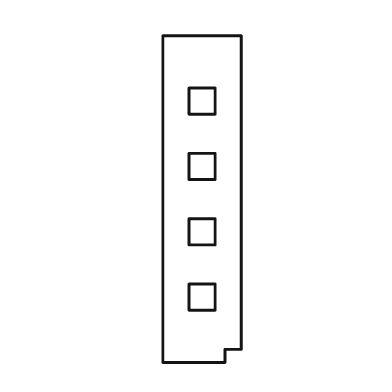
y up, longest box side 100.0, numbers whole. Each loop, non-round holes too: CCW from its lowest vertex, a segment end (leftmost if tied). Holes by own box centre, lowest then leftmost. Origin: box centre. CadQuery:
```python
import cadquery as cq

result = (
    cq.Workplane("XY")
    .moveTo(-12.0, -50.0)
    .lineTo(7.0, -50.0)
    .lineTo(7.0, -46.0)
    .lineTo(12.0, -46.0)
    .lineTo(12.0, 50.0)
    .lineTo(-12.0, 50.0)
    .close()
    .moveTo(-4.0, -34.0)
    .lineTo(4.0, -34.0)
    .lineTo(4.0, -26.0)
    .lineTo(-4.0, -26.0)
    .close()
    .moveTo(-4.0, -14.0)
    .lineTo(4.0, -14.0)
    .lineTo(4.0, -6.0)
    .lineTo(-4.0, -6.0)
    .close()
    .moveTo(-4.0, 6.0)
    .lineTo(4.0, 6.0)
    .lineTo(4.0, 14.0)
    .lineTo(-4.0, 14.0)
    .close()
    .moveTo(-4.0, 26.0)
    .lineTo(4.0, 26.0)
    .lineTo(4.0, 34.0)
    .lineTo(-4.0, 34.0)
    .close()
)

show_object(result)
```